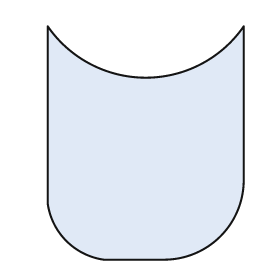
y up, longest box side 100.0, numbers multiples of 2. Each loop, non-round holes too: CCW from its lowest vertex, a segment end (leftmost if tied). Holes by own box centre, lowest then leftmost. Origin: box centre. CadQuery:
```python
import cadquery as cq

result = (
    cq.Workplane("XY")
    .moveTo(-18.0, -50.0)
    .lineTo(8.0, -50.0)
    .threePointArc((32.0, -40.0), (42.0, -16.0))
    .lineTo(42.0, 50.0)
    .threePointArc((0.0, 28.0), (-42.0, 50.0))
    .lineTo(-42.0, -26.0)
    .threePointArc((-34.0, -42.0), (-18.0, -50.0))
    .close()
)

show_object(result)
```